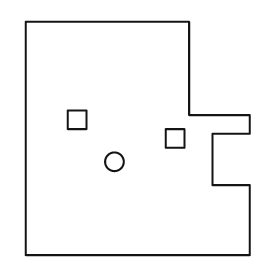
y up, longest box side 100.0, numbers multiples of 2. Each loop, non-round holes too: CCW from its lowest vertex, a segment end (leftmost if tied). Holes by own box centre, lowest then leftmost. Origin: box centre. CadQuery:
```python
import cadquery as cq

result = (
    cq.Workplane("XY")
    .moveTo(-48.0, -50.0)
    .lineTo(48.0, -50.0)
    .lineTo(48.0, -20.0)
    .lineTo(32.0, -20.0)
    .lineTo(32.0, 2.0)
    .lineTo(48.0, 2.0)
    .lineTo(48.0, 10.0)
    .lineTo(22.0, 10.0)
    .lineTo(22.0, 50.0)
    .lineTo(-48.0, 50.0)
    .close()
    .moveTo(-10.0, -10.0)
    .circle(4.0)
    .moveTo(12.0, -4.0)
    .lineTo(20.0, -4.0)
    .lineTo(20.0, 4.0)
    .lineTo(12.0, 4.0)
    .close()
    .moveTo(-30.0, 4.0)
    .lineTo(-22.0, 4.0)
    .lineTo(-22.0, 12.0)
    .lineTo(-30.0, 12.0)
    .close()
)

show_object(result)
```